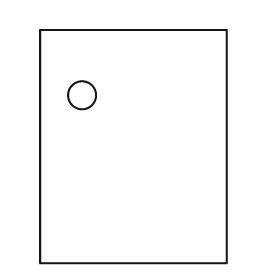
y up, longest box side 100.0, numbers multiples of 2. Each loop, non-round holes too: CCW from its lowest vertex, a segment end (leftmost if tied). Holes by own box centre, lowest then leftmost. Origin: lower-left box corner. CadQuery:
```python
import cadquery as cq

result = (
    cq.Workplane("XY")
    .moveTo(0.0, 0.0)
    .lineTo(80.0, 0.0)
    .lineTo(80.0, 100.0)
    .lineTo(0.0, 100.0)
    .close()
    .moveTo(18.0, 72.0)
    .circle(6.0)
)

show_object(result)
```